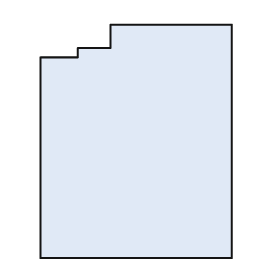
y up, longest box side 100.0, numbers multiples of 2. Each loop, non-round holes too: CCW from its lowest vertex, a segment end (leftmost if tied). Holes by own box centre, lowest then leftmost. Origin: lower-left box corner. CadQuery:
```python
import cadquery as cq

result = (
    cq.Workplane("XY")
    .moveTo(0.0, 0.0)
    .lineTo(82.0, 0.0)
    .lineTo(82.0, 100.0)
    .lineTo(30.0, 100.0)
    .lineTo(30.0, 90.0)
    .lineTo(16.0, 90.0)
    .lineTo(16.0, 86.0)
    .lineTo(0.0, 86.0)
    .close()
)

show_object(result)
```